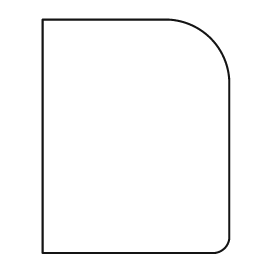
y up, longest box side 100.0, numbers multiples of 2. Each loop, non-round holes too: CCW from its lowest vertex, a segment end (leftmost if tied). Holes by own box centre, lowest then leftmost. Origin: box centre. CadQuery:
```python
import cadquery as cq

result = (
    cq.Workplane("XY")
    .moveTo(-40.0, -50.0)
    .lineTo(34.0, -50.0)
    .threePointArc((38.0, -48.0), (40.0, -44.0))
    .lineTo(40.0, 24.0)
    .threePointArc((32.0, 42.0), (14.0, 50.0))
    .lineTo(-40.0, 50.0)
    .close()
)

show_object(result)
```